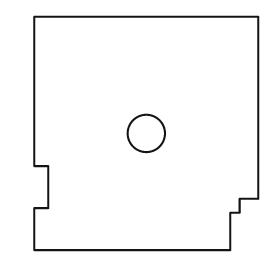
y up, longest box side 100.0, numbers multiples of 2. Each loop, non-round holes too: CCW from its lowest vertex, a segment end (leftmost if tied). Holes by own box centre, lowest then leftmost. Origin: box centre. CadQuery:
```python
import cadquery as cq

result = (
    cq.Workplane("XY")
    .moveTo(-48.0, -50.0)
    .lineTo(36.0, -50.0)
    .lineTo(36.0, -34.0)
    .lineTo(40.0, -34.0)
    .lineTo(40.0, -28.0)
    .lineTo(48.0, -28.0)
    .lineTo(48.0, 50.0)
    .lineTo(-48.0, 50.0)
    .lineTo(-48.0, -14.0)
    .lineTo(-42.0, -14.0)
    .lineTo(-42.0, -32.0)
    .lineTo(-48.0, -32.0)
    .close()
    .moveTo(0.0, 0.0)
    .circle(8.0)
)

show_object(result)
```